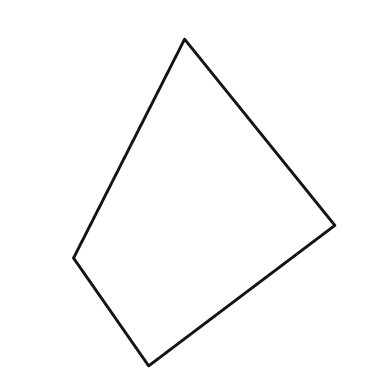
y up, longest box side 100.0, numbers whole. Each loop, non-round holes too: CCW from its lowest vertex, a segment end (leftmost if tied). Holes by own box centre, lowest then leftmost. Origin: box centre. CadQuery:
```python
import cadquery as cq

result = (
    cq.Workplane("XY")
    .moveTo(-17.0, -50.0)
    .lineTo(40.0, -7.0)
    .lineTo(-6.0, 50.0)
    .lineTo(-40.0, -17.0)
    .close()
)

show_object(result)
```